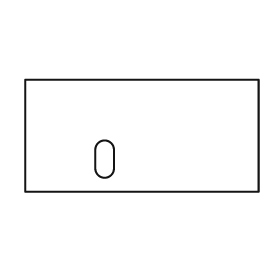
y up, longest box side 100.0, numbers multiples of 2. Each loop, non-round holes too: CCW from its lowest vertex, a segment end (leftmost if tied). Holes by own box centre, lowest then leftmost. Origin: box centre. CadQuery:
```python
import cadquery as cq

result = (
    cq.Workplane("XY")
    .moveTo(-50.0, -24.0)
    .lineTo(50.0, -24.0)
    .lineTo(50.0, 24.0)
    .lineTo(-50.0, 24.0)
    .close()
    .moveTo(-20.0, -14.0)
    .threePointArc((-16.0, -18.0), (-12.0, -14.0))
    .lineTo(-12.0, -6.0)
    .threePointArc((-16.0, -2.0), (-20.0, -6.0))
    .close()
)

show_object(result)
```